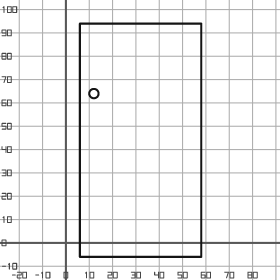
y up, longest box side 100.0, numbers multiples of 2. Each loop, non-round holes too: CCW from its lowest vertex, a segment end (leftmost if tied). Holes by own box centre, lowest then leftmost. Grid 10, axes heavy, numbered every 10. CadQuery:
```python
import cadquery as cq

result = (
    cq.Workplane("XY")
    .moveTo(6.0, -6.0)
    .lineTo(58.0, -6.0)
    .lineTo(58.0, 94.0)
    .lineTo(6.0, 94.0)
    .close()
    .moveTo(12.0, 64.0)
    .circle(2.0)
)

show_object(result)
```